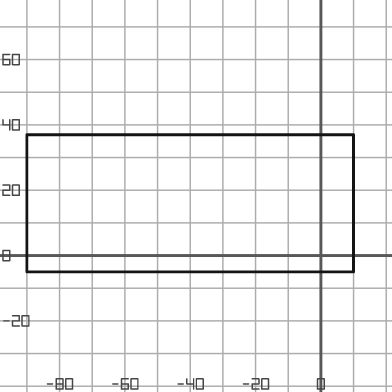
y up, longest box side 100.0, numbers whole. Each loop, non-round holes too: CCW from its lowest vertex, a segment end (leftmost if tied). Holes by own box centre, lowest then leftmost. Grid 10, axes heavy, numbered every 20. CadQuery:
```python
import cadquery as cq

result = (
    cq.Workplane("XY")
    .moveTo(-90.0, -5.0)
    .lineTo(10.0, -5.0)
    .lineTo(10.0, 37.0)
    .lineTo(-90.0, 37.0)
    .close()
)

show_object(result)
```